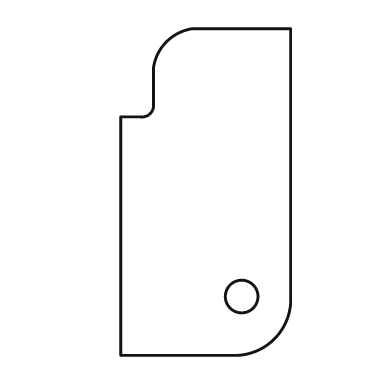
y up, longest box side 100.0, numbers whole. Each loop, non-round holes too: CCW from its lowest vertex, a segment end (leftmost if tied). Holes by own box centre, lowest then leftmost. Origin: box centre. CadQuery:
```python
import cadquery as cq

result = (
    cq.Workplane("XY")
    .moveTo(-26.0, -50.0)
    .lineTo(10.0, -50.0)
    .threePointArc((21.0, -45.0), (26.0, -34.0))
    .lineTo(26.0, 50.0)
    .lineTo(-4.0, 50.0)
    .threePointArc((-12.0, 46.0), (-16.0, 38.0))
    .lineTo(-16.0, 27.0)
    .threePointArc((-17.0, 24.0), (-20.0, 23.0))
    .lineTo(-26.0, 23.0)
    .close()
    .moveTo(11.0, -32.0)
    .circle(5.0)
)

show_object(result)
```